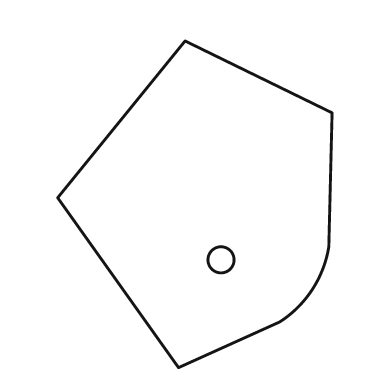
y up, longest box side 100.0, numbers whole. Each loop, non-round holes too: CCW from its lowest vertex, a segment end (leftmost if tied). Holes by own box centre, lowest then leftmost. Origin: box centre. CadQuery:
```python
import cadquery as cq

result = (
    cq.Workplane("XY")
    .moveTo(-5.0, -50.0)
    .lineTo(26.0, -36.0)
    .threePointArc((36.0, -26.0), (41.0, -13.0))
    .lineTo(42.0, 28.0)
    .lineTo(-3.0, 50.0)
    .lineTo(-42.0, 2.0)
    .close()
    .moveTo(8.0, -17.0)
    .circle(4.0)
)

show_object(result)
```